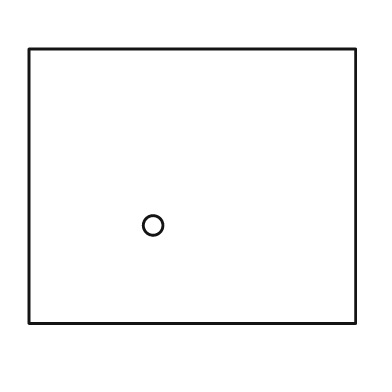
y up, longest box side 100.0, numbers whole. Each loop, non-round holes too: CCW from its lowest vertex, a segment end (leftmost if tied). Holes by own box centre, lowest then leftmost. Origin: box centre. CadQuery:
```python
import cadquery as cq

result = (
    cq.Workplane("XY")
    .moveTo(-50.0, -42.0)
    .lineTo(50.0, -42.0)
    .lineTo(50.0, 42.0)
    .lineTo(-50.0, 42.0)
    .close()
    .moveTo(-12.0, -12.0)
    .circle(3.0)
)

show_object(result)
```